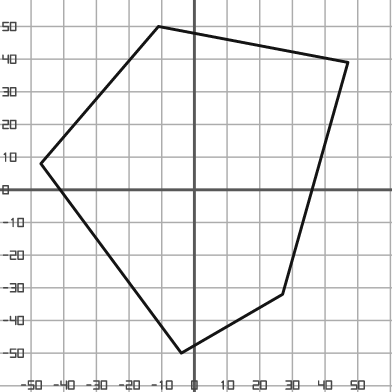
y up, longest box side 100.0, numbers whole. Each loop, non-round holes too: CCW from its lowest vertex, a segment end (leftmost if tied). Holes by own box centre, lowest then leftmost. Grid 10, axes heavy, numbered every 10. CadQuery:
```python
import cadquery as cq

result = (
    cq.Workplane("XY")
    .moveTo(-4.0, -50.0)
    .lineTo(27.0, -32.0)
    .lineTo(47.0, 39.0)
    .lineTo(-11.0, 50.0)
    .lineTo(-47.0, 8.0)
    .close()
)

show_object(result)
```